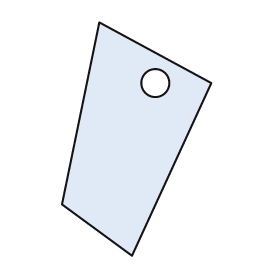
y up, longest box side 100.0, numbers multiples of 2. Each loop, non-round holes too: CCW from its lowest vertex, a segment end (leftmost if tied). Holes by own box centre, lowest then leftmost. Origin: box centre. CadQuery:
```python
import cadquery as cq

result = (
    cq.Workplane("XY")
    .moveTo(-2.0, -50.0)
    .lineTo(32.0, 24.0)
    .lineTo(-16.0, 50.0)
    .lineTo(-32.0, -28.0)
    .close()
    .moveTo(8.0, 24.0)
    .circle(6.0)
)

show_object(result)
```